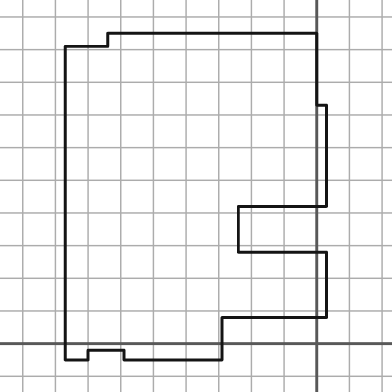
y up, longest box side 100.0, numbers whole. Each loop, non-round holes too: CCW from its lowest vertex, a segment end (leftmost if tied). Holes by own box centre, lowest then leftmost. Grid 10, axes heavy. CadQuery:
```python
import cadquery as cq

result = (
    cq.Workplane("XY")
    .moveTo(-77.0, -5.0)
    .lineTo(-70.0, -5.0)
    .lineTo(-70.0, -2.0)
    .lineTo(-59.0, -2.0)
    .lineTo(-59.0, -5.0)
    .lineTo(-29.0, -5.0)
    .lineTo(-29.0, 8.0)
    .lineTo(3.0, 8.0)
    .lineTo(3.0, 28.0)
    .lineTo(-24.0, 28.0)
    .lineTo(-24.0, 42.0)
    .lineTo(3.0, 42.0)
    .lineTo(3.0, 73.0)
    .lineTo(0.0, 73.0)
    .lineTo(0.0, 95.0)
    .lineTo(-64.0, 95.0)
    .lineTo(-64.0, 91.0)
    .lineTo(-77.0, 91.0)
    .close()
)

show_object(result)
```